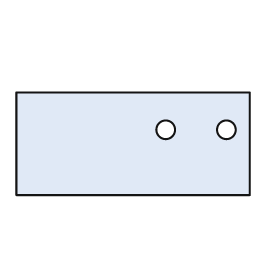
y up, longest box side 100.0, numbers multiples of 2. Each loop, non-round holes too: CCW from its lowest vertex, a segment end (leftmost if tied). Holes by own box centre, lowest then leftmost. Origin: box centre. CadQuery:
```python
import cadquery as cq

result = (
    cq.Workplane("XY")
    .moveTo(-50.0, -22.0)
    .lineTo(50.0, -22.0)
    .lineTo(50.0, 22.0)
    .lineTo(-50.0, 22.0)
    .close()
    .moveTo(14.0, 6.0)
    .circle(4.0)
    .moveTo(40.0, 6.0)
    .circle(4.0)
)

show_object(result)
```